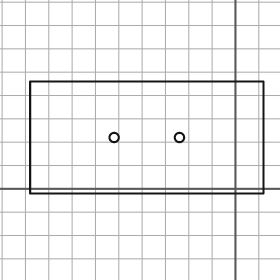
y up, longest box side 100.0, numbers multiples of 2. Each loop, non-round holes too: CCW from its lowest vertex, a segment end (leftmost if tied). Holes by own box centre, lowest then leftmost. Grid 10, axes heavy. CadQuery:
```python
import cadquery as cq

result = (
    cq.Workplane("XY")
    .moveTo(-88.0, -2.0)
    .lineTo(12.0, -2.0)
    .lineTo(12.0, 46.0)
    .lineTo(-88.0, 46.0)
    .close()
    .moveTo(-52.0, 22.0)
    .circle(2.0)
    .moveTo(-24.0, 22.0)
    .circle(2.0)
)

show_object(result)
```